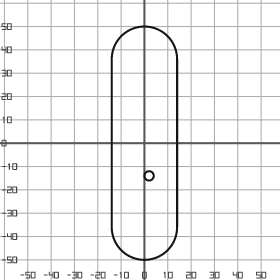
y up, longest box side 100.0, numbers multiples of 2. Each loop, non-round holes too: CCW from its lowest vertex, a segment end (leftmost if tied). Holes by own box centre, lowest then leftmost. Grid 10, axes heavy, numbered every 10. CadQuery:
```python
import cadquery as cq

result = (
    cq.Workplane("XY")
    .moveTo(-14.0, -36.0)
    .threePointArc((0.0, -50.0), (14.0, -36.0))
    .lineTo(14.0, 36.0)
    .threePointArc((0.0, 50.0), (-14.0, 36.0))
    .close()
    .moveTo(2.0, -14.0)
    .circle(2.0)
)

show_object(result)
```